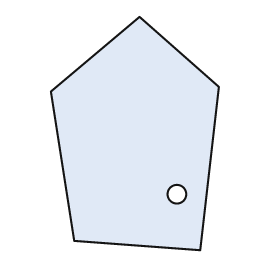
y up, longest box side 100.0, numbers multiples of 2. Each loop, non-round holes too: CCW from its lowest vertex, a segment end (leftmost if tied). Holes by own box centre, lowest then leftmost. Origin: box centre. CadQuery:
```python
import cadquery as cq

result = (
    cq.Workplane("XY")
    .moveTo(28.0, -50.0)
    .lineTo(36.0, 20.0)
    .lineTo(2.0, 50.0)
    .lineTo(-36.0, 18.0)
    .lineTo(-26.0, -46.0)
    .close()
    .moveTo(18.0, -26.0)
    .circle(4.0)
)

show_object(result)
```